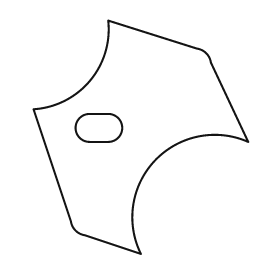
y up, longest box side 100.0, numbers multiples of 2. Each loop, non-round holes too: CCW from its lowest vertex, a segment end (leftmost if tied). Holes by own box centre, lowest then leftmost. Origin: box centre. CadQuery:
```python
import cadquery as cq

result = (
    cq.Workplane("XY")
    .moveTo(0.0, -50.0)
    .threePointArc((6.0, -10.0), (46.0, -2.0))
    .lineTo(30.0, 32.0)
    .threePointArc((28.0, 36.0), (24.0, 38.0))
    .lineTo(-14.0, 50.0)
    .threePointArc((-22.0, 24.0), (-46.0, 12.0))
    .lineTo(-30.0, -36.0)
    .threePointArc((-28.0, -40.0), (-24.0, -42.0))
    .close()
    .moveTo(-22.0, -2.0)
    .lineTo(-14.0, -2.0)
    .threePointArc((-8.0, 4.0), (-14.0, 10.0))
    .lineTo(-22.0, 10.0)
    .threePointArc((-28.0, 4.0), (-22.0, -2.0))
    .close()
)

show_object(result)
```